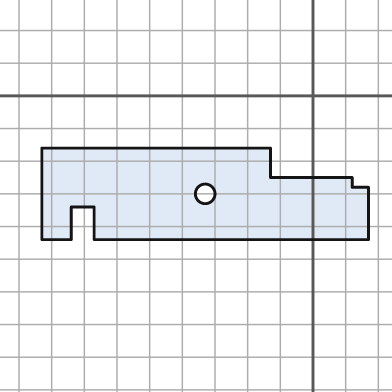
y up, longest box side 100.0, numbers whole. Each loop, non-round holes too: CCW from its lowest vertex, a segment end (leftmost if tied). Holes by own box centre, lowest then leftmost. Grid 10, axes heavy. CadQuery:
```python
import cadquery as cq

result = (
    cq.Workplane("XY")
    .moveTo(-83.0, -44.0)
    .lineTo(-74.0, -44.0)
    .lineTo(-74.0, -34.0)
    .lineTo(-67.0, -34.0)
    .lineTo(-67.0, -44.0)
    .lineTo(17.0, -44.0)
    .lineTo(17.0, -28.0)
    .lineTo(12.0, -28.0)
    .lineTo(12.0, -25.0)
    .lineTo(-13.0, -25.0)
    .lineTo(-13.0, -16.0)
    .lineTo(-83.0, -16.0)
    .close()
    .moveTo(-33.0, -30.0)
    .circle(3.0)
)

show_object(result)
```